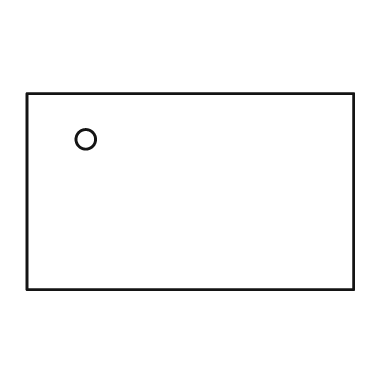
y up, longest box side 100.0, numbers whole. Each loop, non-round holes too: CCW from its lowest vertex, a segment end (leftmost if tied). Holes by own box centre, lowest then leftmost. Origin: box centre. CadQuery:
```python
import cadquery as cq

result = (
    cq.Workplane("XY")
    .moveTo(-50.0, -30.0)
    .lineTo(50.0, -30.0)
    .lineTo(50.0, 30.0)
    .lineTo(-50.0, 30.0)
    .close()
    .moveTo(-32.0, 16.0)
    .circle(3.0)
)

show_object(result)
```